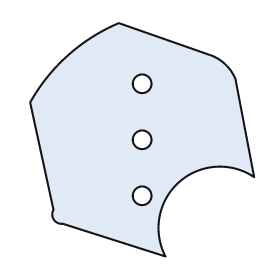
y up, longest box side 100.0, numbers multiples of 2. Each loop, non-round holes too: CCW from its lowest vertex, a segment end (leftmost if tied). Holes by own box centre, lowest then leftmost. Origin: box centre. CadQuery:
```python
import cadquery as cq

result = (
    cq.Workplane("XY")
    .moveTo(10.0, -50.0)
    .threePointArc((16.0, -18.0), (48.0, -16.0))
    .lineTo(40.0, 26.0)
    .threePointArc((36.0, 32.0), (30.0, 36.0))
    .lineTo(-10.0, 50.0)
    .threePointArc((-32.0, 36.0), (-48.0, 16.0))
    .lineTo(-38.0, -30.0)
    .threePointArc((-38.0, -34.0), (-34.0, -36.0))
    .close()
    .moveTo(0.0, -24.0)
    .circle(4.0)
    .moveTo(0.0, 0.0)
    .circle(4.0)
    .moveTo(0.0, 24.0)
    .circle(4.0)
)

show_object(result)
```